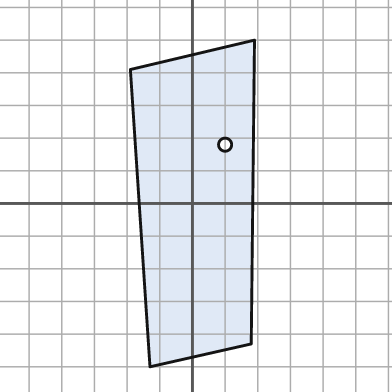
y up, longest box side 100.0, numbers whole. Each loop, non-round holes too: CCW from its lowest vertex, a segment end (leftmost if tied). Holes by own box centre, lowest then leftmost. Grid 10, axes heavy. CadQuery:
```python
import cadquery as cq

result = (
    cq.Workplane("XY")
    .moveTo(-13.0, -50.0)
    .lineTo(18.0, -43.0)
    .lineTo(19.0, 50.0)
    .lineTo(-19.0, 41.0)
    .close()
    .moveTo(10.0, 18.0)
    .circle(2.0)
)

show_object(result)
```